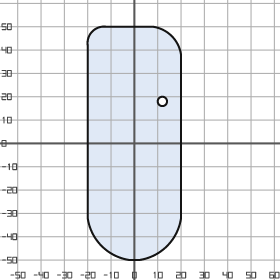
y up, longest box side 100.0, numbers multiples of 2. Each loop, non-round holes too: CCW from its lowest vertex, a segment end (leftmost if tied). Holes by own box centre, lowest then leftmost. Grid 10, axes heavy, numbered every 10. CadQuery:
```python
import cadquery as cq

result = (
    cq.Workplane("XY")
    .moveTo(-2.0, -50.0)
    .lineTo(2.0, -50.0)
    .threePointArc((14.0, -44.0), (20.0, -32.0))
    .lineTo(20.0, 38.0)
    .threePointArc((16.0, 46.0), (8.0, 50.0))
    .lineTo(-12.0, 50.0)
    .threePointArc((-18.0, 48.0), (-20.0, 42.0))
    .lineTo(-20.0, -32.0)
    .threePointArc((-14.0, -44.0), (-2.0, -50.0))
    .close()
    .moveTo(12.0, 18.0)
    .circle(2.0)
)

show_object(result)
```